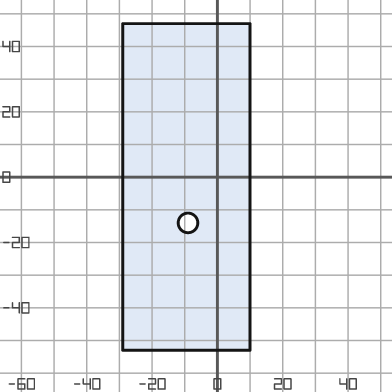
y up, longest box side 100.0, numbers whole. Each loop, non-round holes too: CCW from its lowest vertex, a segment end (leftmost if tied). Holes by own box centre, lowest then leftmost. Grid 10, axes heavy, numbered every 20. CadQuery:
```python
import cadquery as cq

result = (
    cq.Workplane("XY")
    .moveTo(-29.0, -53.0)
    .lineTo(10.0, -53.0)
    .lineTo(10.0, 47.0)
    .lineTo(-29.0, 47.0)
    .close()
    .moveTo(-9.0, -14.0)
    .circle(3.0)
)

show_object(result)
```